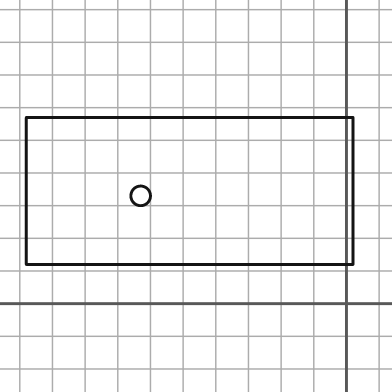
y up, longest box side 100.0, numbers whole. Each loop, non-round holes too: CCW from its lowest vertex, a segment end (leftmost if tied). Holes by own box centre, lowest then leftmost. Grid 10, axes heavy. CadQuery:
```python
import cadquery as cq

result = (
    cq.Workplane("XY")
    .moveTo(-98.0, 12.0)
    .lineTo(2.0, 12.0)
    .lineTo(2.0, 57.0)
    .lineTo(-98.0, 57.0)
    .close()
    .moveTo(-63.0, 33.0)
    .circle(3.0)
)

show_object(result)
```